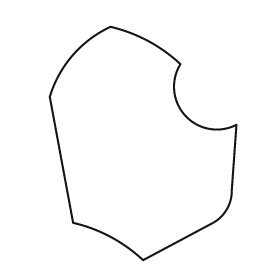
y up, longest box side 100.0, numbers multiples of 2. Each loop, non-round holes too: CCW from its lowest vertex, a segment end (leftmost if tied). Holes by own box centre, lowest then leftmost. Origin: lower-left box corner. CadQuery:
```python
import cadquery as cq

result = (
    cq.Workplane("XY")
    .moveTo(40.0, 0.0)
    .lineTo(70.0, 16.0)
    .threePointArc((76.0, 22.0), (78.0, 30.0))
    .lineTo(80.0, 58.0)
    .threePointArc((58.0, 62.0), (56.0, 84.0))
    .threePointArc((42.0, 94.0), (26.0, 100.0))
    .threePointArc((10.0, 88.0), (0.0, 70.0))
    .lineTo(10.0, 16.0)
    .threePointArc((26.0, 10.0), (40.0, 0.0))
    .close()
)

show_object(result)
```